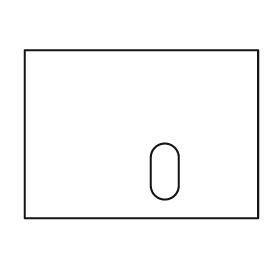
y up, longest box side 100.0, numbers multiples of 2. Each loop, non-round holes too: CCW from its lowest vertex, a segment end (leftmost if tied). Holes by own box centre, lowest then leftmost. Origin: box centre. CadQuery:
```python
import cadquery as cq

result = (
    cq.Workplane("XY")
    .moveTo(-50.0, -36.0)
    .lineTo(50.0, -36.0)
    .lineTo(50.0, 36.0)
    .lineTo(-50.0, 36.0)
    .close()
    .moveTo(4.0, -22.0)
    .threePointArc((10.0, -28.0), (16.0, -22.0))
    .lineTo(16.0, -10.0)
    .threePointArc((10.0, -4.0), (4.0, -10.0))
    .close()
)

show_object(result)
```